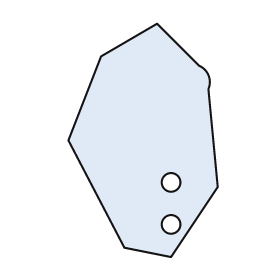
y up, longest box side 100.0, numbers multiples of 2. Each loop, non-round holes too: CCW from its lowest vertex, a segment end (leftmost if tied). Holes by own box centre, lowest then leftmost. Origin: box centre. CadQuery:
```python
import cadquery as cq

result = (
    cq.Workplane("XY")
    .moveTo(12.0, -50.0)
    .lineTo(32.0, -20.0)
    .lineTo(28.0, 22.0)
    .threePointArc((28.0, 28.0), (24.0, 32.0))
    .lineTo(6.0, 50.0)
    .lineTo(-18.0, 36.0)
    .lineTo(-32.0, 0.0)
    .lineTo(-8.0, -46.0)
    .close()
    .moveTo(12.0, -36.0)
    .circle(4.0)
    .moveTo(12.0, -18.0)
    .circle(4.0)
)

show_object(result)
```